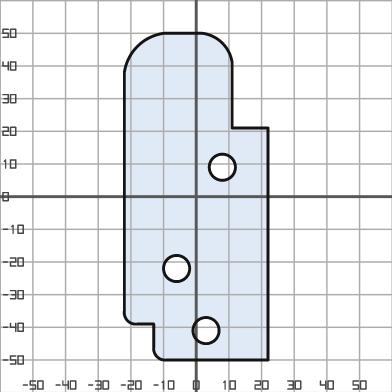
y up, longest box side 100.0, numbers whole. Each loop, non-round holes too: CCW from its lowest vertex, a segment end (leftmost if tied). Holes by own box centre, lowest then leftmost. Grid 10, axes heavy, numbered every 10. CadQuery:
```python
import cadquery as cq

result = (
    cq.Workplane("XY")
    .moveTo(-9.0, -50.0)
    .lineTo(22.0, -50.0)
    .lineTo(22.0, 21.0)
    .lineTo(11.0, 21.0)
    .lineTo(11.0, 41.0)
    .threePointArc((8.0, 47.0), (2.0, 50.0))
    .lineTo(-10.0, 50.0)
    .threePointArc((-18.0, 46.0), (-22.0, 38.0))
    .lineTo(-22.0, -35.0)
    .threePointArc((-21.0, -38.0), (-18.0, -39.0))
    .lineTo(-13.0, -39.0)
    .lineTo(-13.0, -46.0)
    .threePointArc((-12.0, -49.0), (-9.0, -50.0))
    .close()
    .moveTo(3.0, -41.0)
    .circle(4.0)
    .moveTo(-6.0, -22.0)
    .circle(4.0)
    .moveTo(8.0, 9.0)
    .circle(4.0)
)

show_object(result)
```